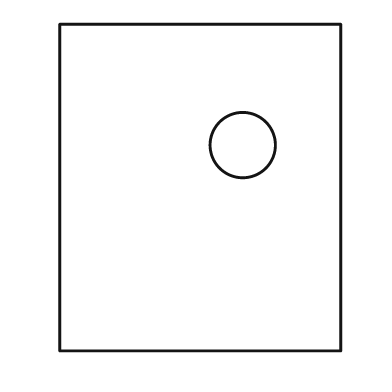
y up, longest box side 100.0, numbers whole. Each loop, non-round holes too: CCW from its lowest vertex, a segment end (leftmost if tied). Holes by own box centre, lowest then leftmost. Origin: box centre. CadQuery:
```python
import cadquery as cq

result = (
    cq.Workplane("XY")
    .moveTo(-43.0, -50.0)
    .lineTo(43.0, -50.0)
    .lineTo(43.0, 50.0)
    .lineTo(-43.0, 50.0)
    .close()
    .moveTo(13.0, 13.0)
    .circle(10.0)
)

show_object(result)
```